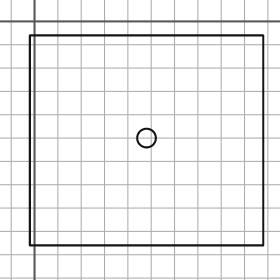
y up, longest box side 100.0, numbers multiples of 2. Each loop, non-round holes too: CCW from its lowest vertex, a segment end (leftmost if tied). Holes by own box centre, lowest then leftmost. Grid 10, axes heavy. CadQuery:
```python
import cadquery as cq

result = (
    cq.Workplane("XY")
    .moveTo(-2.0, -96.0)
    .lineTo(98.0, -96.0)
    .lineTo(98.0, -6.0)
    .lineTo(-2.0, -6.0)
    .close()
    .moveTo(48.0, -50.0)
    .circle(4.0)
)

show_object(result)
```